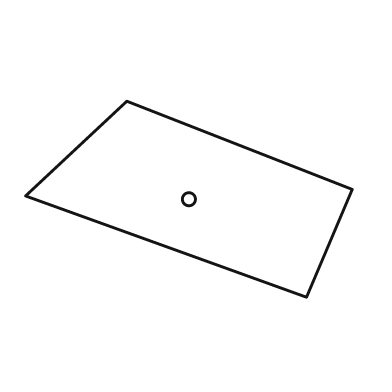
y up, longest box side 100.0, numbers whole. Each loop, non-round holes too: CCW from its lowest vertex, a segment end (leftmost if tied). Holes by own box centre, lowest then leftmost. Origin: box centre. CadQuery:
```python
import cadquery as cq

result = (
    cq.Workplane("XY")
    .moveTo(36.0, -30.0)
    .lineTo(50.0, 3.0)
    .lineTo(-19.0, 30.0)
    .lineTo(-50.0, 1.0)
    .close()
    .moveTo(0.0, 0.0)
    .circle(2.0)
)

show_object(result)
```